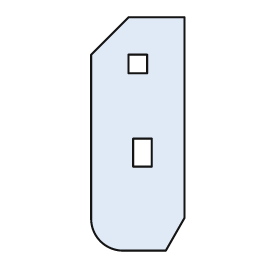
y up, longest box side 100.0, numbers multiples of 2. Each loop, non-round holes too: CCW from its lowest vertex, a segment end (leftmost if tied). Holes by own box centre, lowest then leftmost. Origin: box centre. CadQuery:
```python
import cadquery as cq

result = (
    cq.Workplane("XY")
    .moveTo(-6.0, -50.0)
    .lineTo(12.0, -50.0)
    .lineTo(20.0, -36.0)
    .lineTo(20.0, 50.0)
    .lineTo(-4.0, 50.0)
    .lineTo(-20.0, 34.0)
    .lineTo(-20.0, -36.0)
    .threePointArc((-16.0, -46.0), (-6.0, -50.0))
    .close()
    .moveTo(-2.0, -14.0)
    .lineTo(6.0, -14.0)
    .lineTo(6.0, -2.0)
    .lineTo(-2.0, -2.0)
    .close()
    .moveTo(-4.0, 26.0)
    .lineTo(4.0, 26.0)
    .lineTo(4.0, 34.0)
    .lineTo(-4.0, 34.0)
    .close()
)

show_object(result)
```